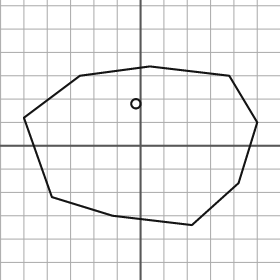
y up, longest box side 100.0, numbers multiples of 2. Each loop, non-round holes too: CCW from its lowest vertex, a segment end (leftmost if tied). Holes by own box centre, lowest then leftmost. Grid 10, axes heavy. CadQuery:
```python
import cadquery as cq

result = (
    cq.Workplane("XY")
    .moveTo(22.0, -34.0)
    .lineTo(42.0, -16.0)
    .lineTo(50.0, 10.0)
    .lineTo(38.0, 30.0)
    .lineTo(4.0, 34.0)
    .lineTo(-26.0, 30.0)
    .lineTo(-50.0, 12.0)
    .lineTo(-38.0, -22.0)
    .lineTo(-12.0, -30.0)
    .close()
    .moveTo(-2.0, 18.0)
    .circle(2.0)
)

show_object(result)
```